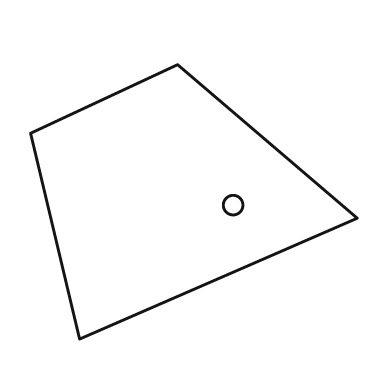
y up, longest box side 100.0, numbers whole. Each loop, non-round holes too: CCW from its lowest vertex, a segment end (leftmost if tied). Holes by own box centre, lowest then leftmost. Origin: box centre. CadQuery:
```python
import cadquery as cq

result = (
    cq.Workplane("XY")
    .moveTo(-35.0, -42.0)
    .lineTo(50.0, -5.0)
    .lineTo(-5.0, 42.0)
    .lineTo(-50.0, 21.0)
    .close()
    .moveTo(12.0, -1.0)
    .circle(3.0)
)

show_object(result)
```